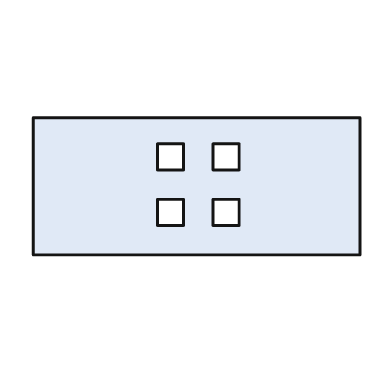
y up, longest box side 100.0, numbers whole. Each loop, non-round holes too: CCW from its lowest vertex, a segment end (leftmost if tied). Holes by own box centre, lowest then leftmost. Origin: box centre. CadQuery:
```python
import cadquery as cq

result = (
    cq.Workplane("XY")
    .moveTo(-50.0, -21.0)
    .lineTo(50.0, -21.0)
    .lineTo(50.0, 21.0)
    .lineTo(-50.0, 21.0)
    .close()
    .moveTo(-12.0, -12.0)
    .lineTo(-4.0, -12.0)
    .lineTo(-4.0, -4.0)
    .lineTo(-12.0, -4.0)
    .close()
    .moveTo(5.0, -12.0)
    .lineTo(13.0, -12.0)
    .lineTo(13.0, -4.0)
    .lineTo(5.0, -4.0)
    .close()
    .moveTo(-12.0, 5.0)
    .lineTo(-4.0, 5.0)
    .lineTo(-4.0, 13.0)
    .lineTo(-12.0, 13.0)
    .close()
    .moveTo(5.0, 5.0)
    .lineTo(13.0, 5.0)
    .lineTo(13.0, 13.0)
    .lineTo(5.0, 13.0)
    .close()
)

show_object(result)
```